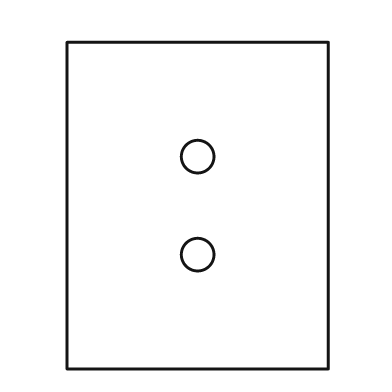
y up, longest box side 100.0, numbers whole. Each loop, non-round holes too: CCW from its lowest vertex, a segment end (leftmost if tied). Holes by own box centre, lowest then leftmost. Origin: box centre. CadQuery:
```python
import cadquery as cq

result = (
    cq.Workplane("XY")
    .moveTo(-40.0, -50.0)
    .lineTo(40.0, -50.0)
    .lineTo(40.0, 50.0)
    .lineTo(-40.0, 50.0)
    .close()
    .moveTo(0.0, -15.0)
    .circle(5.0)
    .moveTo(0.0, 15.0)
    .circle(5.0)
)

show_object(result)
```